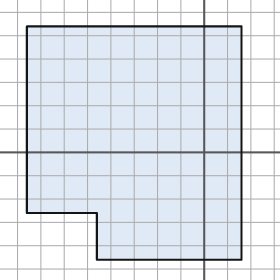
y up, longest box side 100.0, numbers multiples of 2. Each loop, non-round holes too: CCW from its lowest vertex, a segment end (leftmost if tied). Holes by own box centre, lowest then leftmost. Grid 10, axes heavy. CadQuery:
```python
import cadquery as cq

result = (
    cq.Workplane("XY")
    .moveTo(-46.0, -46.0)
    .lineTo(16.0, -46.0)
    .lineTo(16.0, 54.0)
    .lineTo(-76.0, 54.0)
    .lineTo(-76.0, -26.0)
    .lineTo(-46.0, -26.0)
    .close()
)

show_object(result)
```